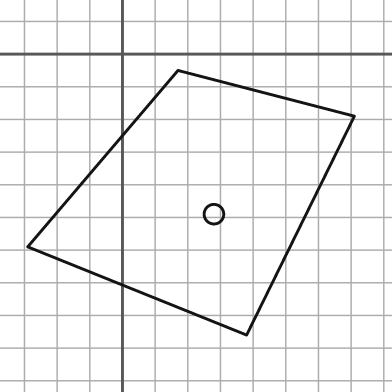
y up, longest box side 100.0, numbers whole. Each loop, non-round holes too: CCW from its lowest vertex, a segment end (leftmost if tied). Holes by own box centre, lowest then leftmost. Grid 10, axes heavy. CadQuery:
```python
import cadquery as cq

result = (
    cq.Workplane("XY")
    .moveTo(38.0, -86.0)
    .lineTo(71.0, -19.0)
    .lineTo(17.0, -5.0)
    .lineTo(-29.0, -59.0)
    .close()
    .moveTo(28.0, -49.0)
    .circle(3.0)
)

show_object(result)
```